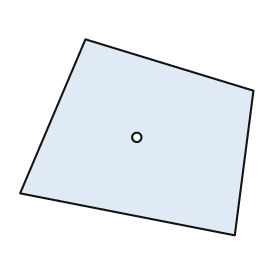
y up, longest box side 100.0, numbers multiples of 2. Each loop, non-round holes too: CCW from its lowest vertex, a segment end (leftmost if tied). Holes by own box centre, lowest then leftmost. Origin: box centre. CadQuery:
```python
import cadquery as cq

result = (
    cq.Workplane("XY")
    .moveTo(42.0, -42.0)
    .lineTo(50.0, 20.0)
    .lineTo(-22.0, 42.0)
    .lineTo(-50.0, -24.0)
    .close()
    .moveTo(0.0, 0.0)
    .circle(2.0)
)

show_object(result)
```